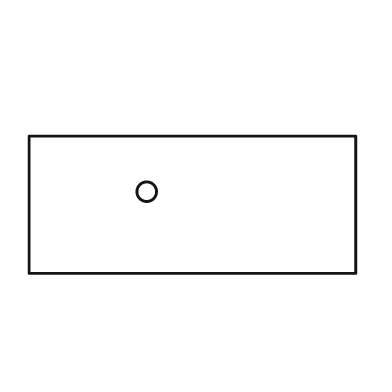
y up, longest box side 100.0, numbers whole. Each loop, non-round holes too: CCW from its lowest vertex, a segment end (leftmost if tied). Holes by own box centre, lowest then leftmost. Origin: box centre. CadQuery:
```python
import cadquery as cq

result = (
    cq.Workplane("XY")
    .moveTo(-50.0, -21.0)
    .lineTo(50.0, -21.0)
    .lineTo(50.0, 21.0)
    .lineTo(-50.0, 21.0)
    .close()
    .moveTo(-14.0, 4.0)
    .circle(3.0)
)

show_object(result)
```